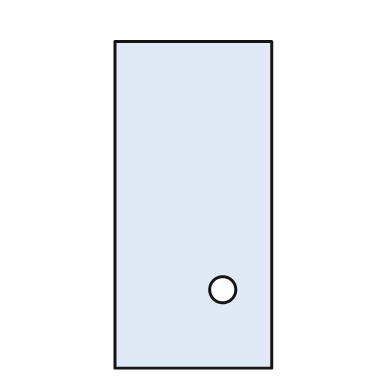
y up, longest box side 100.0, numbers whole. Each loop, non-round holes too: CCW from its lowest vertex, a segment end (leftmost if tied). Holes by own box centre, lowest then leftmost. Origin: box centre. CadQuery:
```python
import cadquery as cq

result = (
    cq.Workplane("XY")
    .moveTo(-24.0, -50.0)
    .lineTo(24.0, -50.0)
    .lineTo(24.0, 50.0)
    .lineTo(-24.0, 50.0)
    .close()
    .moveTo(9.0, -26.0)
    .circle(4.0)
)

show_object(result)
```